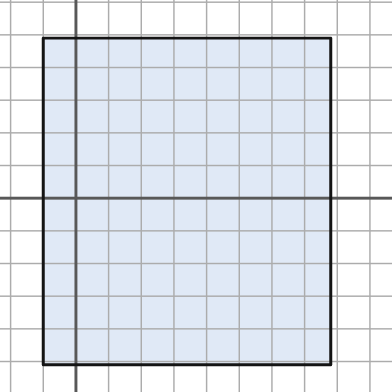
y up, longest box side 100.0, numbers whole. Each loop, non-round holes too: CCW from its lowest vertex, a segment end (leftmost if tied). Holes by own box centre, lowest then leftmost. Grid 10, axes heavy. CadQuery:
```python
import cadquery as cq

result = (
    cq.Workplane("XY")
    .moveTo(-10.0, -51.0)
    .lineTo(78.0, -51.0)
    .lineTo(78.0, 49.0)
    .lineTo(-10.0, 49.0)
    .close()
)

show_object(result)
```